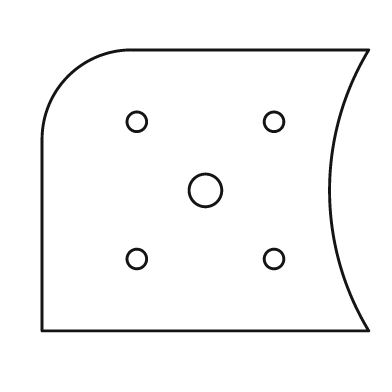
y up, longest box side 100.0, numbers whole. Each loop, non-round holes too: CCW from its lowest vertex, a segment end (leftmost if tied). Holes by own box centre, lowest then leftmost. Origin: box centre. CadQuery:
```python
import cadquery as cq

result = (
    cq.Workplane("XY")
    .moveTo(-50.0, -43.0)
    .lineTo(50.0, -43.0)
    .threePointArc((38.0, 0.0), (50.0, 43.0))
    .lineTo(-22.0, 43.0)
    .threePointArc((-42.0, 35.0), (-50.0, 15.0))
    .close()
    .moveTo(-21.0, -21.0)
    .circle(3.0)
    .moveTo(21.0, -21.0)
    .circle(3.0)
    .moveTo(0.0, 0.0)
    .circle(5.0)
    .moveTo(-21.0, 21.0)
    .circle(3.0)
    .moveTo(21.0, 21.0)
    .circle(3.0)
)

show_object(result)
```